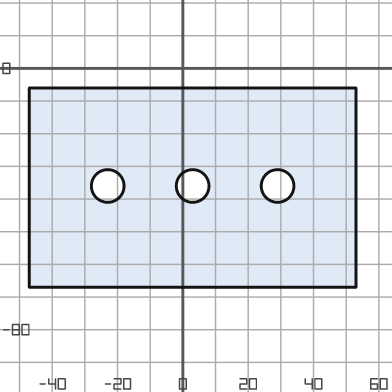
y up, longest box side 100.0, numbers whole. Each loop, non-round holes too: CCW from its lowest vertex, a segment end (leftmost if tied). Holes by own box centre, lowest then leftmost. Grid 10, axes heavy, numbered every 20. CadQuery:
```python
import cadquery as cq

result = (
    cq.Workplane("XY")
    .moveTo(-47.0, -67.0)
    .lineTo(53.0, -67.0)
    .lineTo(53.0, -6.0)
    .lineTo(-47.0, -6.0)
    .close()
    .moveTo(-23.0, -36.0)
    .circle(5.0)
    .moveTo(3.0, -36.0)
    .circle(5.0)
    .moveTo(29.0, -36.0)
    .circle(5.0)
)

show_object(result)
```